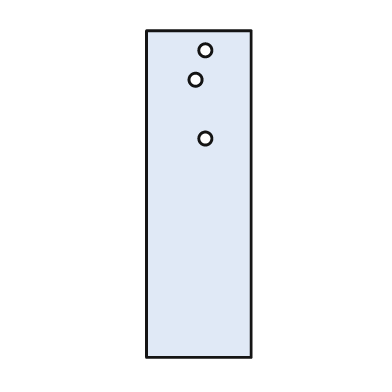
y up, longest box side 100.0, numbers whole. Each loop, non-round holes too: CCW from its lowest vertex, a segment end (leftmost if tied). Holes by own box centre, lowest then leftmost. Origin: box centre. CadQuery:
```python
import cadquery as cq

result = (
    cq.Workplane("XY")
    .moveTo(-16.0, -50.0)
    .lineTo(16.0, -50.0)
    .lineTo(16.0, 50.0)
    .lineTo(-16.0, 50.0)
    .close()
    .moveTo(2.0, 17.0)
    .circle(2.0)
    .moveTo(-1.0, 35.0)
    .circle(2.0)
    .moveTo(2.0, 44.0)
    .circle(2.0)
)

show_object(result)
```